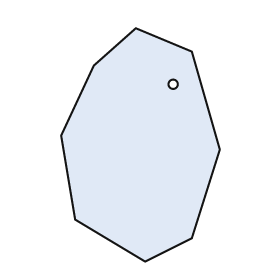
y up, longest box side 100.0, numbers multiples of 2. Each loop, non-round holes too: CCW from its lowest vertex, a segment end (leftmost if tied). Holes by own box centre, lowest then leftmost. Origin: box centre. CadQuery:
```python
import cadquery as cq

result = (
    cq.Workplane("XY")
    .moveTo(2.0, -50.0)
    .lineTo(22.0, -40.0)
    .lineTo(34.0, -2.0)
    .lineTo(22.0, 40.0)
    .lineTo(-2.0, 50.0)
    .lineTo(-20.0, 34.0)
    .lineTo(-34.0, 4.0)
    .lineTo(-28.0, -32.0)
    .close()
    .moveTo(14.0, 26.0)
    .circle(2.0)
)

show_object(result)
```